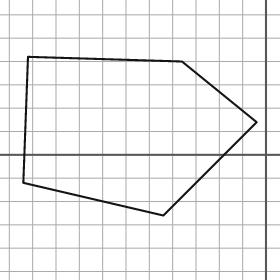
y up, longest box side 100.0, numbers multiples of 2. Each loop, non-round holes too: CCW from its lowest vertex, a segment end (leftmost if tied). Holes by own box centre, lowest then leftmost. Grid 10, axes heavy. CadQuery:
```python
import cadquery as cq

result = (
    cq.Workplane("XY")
    .moveTo(-44.0, -26.0)
    .lineTo(-4.0, 14.0)
    .lineTo(-36.0, 40.0)
    .lineTo(-102.0, 42.0)
    .lineTo(-104.0, -12.0)
    .close()
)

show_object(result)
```